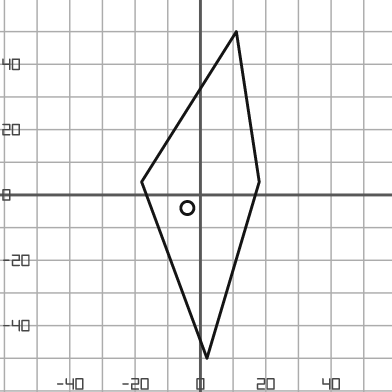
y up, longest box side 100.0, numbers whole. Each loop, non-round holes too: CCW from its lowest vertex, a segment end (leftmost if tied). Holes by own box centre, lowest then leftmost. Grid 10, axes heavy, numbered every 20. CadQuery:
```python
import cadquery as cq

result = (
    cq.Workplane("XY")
    .moveTo(2.0, -50.0)
    .lineTo(18.0, 4.0)
    .lineTo(11.0, 50.0)
    .lineTo(-18.0, 4.0)
    .close()
    .moveTo(-4.0, -4.0)
    .circle(2.0)
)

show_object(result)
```